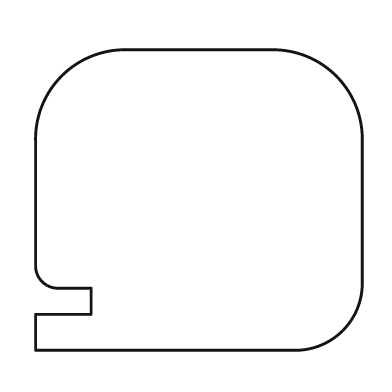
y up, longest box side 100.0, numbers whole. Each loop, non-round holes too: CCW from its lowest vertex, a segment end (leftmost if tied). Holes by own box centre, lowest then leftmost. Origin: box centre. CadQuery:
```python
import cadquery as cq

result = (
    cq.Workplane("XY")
    .moveTo(-50.0, -46.0)
    .lineTo(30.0, -46.0)
    .threePointArc((44.0, -40.0), (50.0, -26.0))
    .lineTo(50.0, 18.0)
    .threePointArc((42.0, 38.0), (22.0, 46.0))
    .lineTo(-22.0, 46.0)
    .threePointArc((-42.0, 38.0), (-50.0, 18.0))
    .lineTo(-50.0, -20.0)
    .threePointArc((-48.0, -25.0), (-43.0, -27.0))
    .lineTo(-33.0, -27.0)
    .lineTo(-33.0, -35.0)
    .lineTo(-50.0, -35.0)
    .close()
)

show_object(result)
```